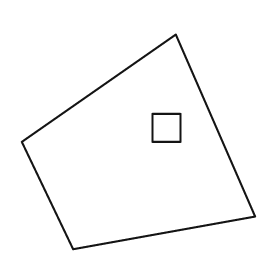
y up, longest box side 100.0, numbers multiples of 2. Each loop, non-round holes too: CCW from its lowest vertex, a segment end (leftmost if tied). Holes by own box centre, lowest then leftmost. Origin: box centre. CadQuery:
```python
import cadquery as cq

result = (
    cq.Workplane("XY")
    .moveTo(-28.0, -46.0)
    .lineTo(50.0, -32.0)
    .lineTo(16.0, 46.0)
    .lineTo(-50.0, 0.0)
    .close()
    .moveTo(6.0, 0.0)
    .lineTo(18.0, 0.0)
    .lineTo(18.0, 12.0)
    .lineTo(6.0, 12.0)
    .close()
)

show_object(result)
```